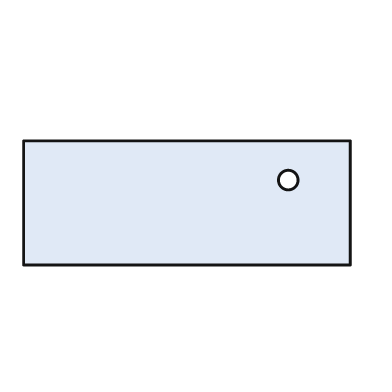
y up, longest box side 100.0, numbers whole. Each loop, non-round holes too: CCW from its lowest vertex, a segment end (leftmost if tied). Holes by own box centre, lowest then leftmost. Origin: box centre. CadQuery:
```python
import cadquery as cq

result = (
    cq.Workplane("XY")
    .moveTo(-50.0, -19.0)
    .lineTo(50.0, -19.0)
    .lineTo(50.0, 19.0)
    .lineTo(-50.0, 19.0)
    .close()
    .moveTo(31.0, 7.0)
    .circle(3.0)
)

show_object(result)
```